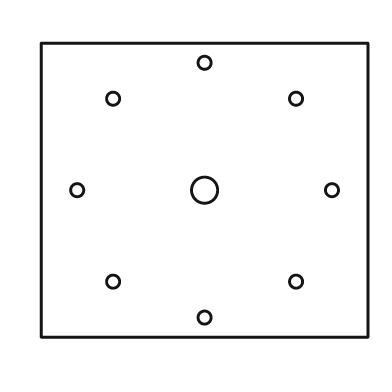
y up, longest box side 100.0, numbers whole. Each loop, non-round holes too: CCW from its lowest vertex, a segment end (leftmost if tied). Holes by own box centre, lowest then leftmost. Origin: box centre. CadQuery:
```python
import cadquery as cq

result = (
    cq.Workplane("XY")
    .moveTo(-50.0, -45.0)
    .lineTo(50.0, -45.0)
    .lineTo(50.0, 45.0)
    .lineTo(-50.0, 45.0)
    .close()
    .moveTo(0.0, -39.0)
    .circle(2.0)
    .moveTo(-28.0, -28.0)
    .circle(2.0)
    .moveTo(28.0, -28.0)
    .circle(2.0)
    .moveTo(-39.0, 0.0)
    .circle(2.0)
    .moveTo(0.0, 0.0)
    .circle(4.0)
    .moveTo(39.0, 0.0)
    .circle(2.0)
    .moveTo(-28.0, 28.0)
    .circle(2.0)
    .moveTo(28.0, 28.0)
    .circle(2.0)
    .moveTo(0.0, 39.0)
    .circle(2.0)
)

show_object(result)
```